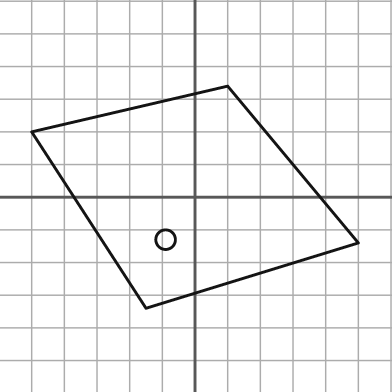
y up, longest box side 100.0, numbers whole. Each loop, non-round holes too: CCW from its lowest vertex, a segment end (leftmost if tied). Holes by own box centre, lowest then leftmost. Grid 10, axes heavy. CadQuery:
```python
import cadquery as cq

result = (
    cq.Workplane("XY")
    .moveTo(-15.0, -34.0)
    .lineTo(50.0, -14.0)
    .lineTo(10.0, 34.0)
    .lineTo(-50.0, 20.0)
    .close()
    .moveTo(-9.0, -13.0)
    .circle(3.0)
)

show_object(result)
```